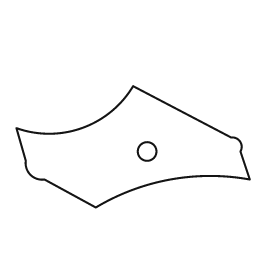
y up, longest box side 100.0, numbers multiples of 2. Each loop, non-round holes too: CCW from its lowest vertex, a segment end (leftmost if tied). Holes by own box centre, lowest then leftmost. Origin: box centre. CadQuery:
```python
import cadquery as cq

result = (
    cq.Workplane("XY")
    .moveTo(-16.0, -26.0)
    .threePointArc((16.0, -14.0), (50.0, -14.0))
    .lineTo(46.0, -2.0)
    .threePointArc((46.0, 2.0), (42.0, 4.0))
    .lineTo(0.0, 26.0)
    .threePointArc((-22.0, 8.0), (-50.0, 8.0))
    .lineTo(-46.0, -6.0)
    .threePointArc((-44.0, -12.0), (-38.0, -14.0))
    .close()
    .moveTo(6.0, -2.0)
    .circle(4.0)
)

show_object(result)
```